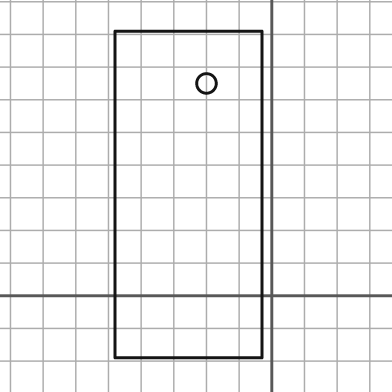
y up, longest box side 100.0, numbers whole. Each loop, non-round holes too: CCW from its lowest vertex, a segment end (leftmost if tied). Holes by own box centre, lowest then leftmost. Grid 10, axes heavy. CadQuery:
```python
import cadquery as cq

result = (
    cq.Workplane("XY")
    .moveTo(-48.0, -19.0)
    .lineTo(-3.0, -19.0)
    .lineTo(-3.0, 81.0)
    .lineTo(-48.0, 81.0)
    .close()
    .moveTo(-20.0, 65.0)
    .circle(3.0)
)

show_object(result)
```